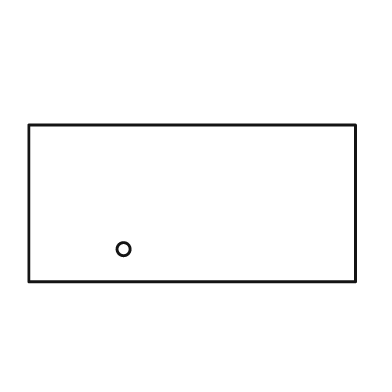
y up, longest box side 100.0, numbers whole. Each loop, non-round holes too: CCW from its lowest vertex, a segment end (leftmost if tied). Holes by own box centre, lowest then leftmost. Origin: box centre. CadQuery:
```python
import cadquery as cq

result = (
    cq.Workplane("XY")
    .moveTo(-50.0, -24.0)
    .lineTo(50.0, -24.0)
    .lineTo(50.0, 24.0)
    .lineTo(-50.0, 24.0)
    .close()
    .moveTo(-21.0, -14.0)
    .circle(2.0)
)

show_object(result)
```